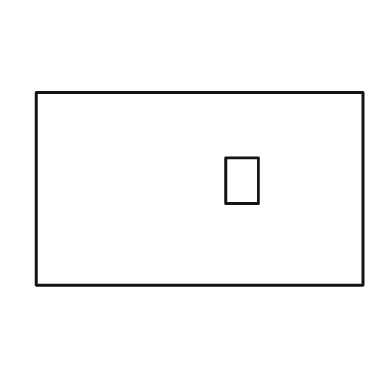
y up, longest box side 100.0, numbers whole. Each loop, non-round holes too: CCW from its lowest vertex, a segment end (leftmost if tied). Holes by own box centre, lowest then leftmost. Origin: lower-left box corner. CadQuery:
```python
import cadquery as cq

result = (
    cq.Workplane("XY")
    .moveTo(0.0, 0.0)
    .lineTo(100.0, 0.0)
    .lineTo(100.0, 59.0)
    .lineTo(0.0, 59.0)
    .close()
    .moveTo(58.0, 25.0)
    .lineTo(68.0, 25.0)
    .lineTo(68.0, 39.0)
    .lineTo(58.0, 39.0)
    .close()
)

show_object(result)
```